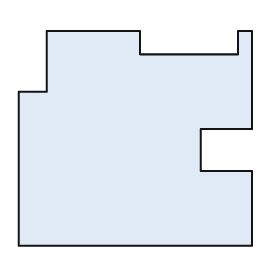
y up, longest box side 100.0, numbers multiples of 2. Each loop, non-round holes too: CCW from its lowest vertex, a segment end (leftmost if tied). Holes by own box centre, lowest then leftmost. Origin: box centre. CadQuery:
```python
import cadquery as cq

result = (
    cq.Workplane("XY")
    .moveTo(-50.0, -46.0)
    .lineTo(50.0, -46.0)
    .lineTo(50.0, -14.0)
    .lineTo(28.0, -14.0)
    .lineTo(28.0, 4.0)
    .lineTo(50.0, 4.0)
    .lineTo(50.0, 46.0)
    .lineTo(44.0, 46.0)
    .lineTo(44.0, 36.0)
    .lineTo(2.0, 36.0)
    .lineTo(2.0, 46.0)
    .lineTo(-38.0, 46.0)
    .lineTo(-38.0, 20.0)
    .lineTo(-50.0, 20.0)
    .close()
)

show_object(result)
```